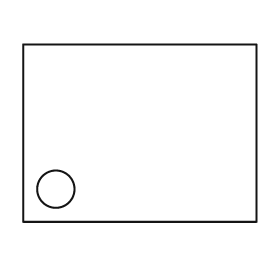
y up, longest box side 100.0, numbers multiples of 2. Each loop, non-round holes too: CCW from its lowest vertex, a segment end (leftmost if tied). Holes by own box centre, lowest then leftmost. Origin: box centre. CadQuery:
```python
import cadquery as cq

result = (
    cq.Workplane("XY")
    .moveTo(-50.0, -38.0)
    .lineTo(50.0, -38.0)
    .lineTo(50.0, 38.0)
    .lineTo(-50.0, 38.0)
    .close()
    .moveTo(-36.0, -24.0)
    .circle(8.0)
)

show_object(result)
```